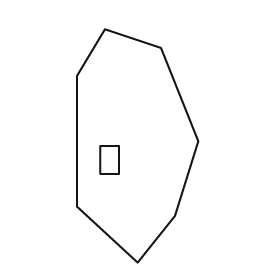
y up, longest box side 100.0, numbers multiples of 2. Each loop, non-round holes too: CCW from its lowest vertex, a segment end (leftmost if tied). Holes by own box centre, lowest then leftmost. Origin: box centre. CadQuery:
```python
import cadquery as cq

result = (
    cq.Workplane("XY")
    .moveTo(0.0, -50.0)
    .lineTo(16.0, -30.0)
    .lineTo(26.0, 2.0)
    .lineTo(10.0, 42.0)
    .lineTo(-14.0, 50.0)
    .lineTo(-26.0, 30.0)
    .lineTo(-26.0, -26.0)
    .close()
    .moveTo(-16.0, -12.0)
    .lineTo(-8.0, -12.0)
    .lineTo(-8.0, 0.0)
    .lineTo(-16.0, 0.0)
    .close()
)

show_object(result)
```